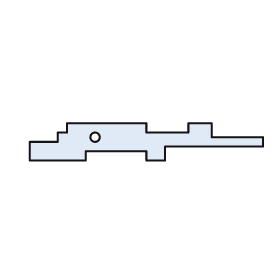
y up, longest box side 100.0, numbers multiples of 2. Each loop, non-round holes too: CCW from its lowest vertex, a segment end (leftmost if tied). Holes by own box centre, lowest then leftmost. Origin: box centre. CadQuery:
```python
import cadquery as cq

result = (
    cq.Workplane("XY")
    .moveTo(-50.0, -8.0)
    .lineTo(-26.0, -8.0)
    .lineTo(-26.0, -4.0)
    .lineTo(0.0, -4.0)
    .lineTo(0.0, -8.0)
    .lineTo(8.0, -8.0)
    .lineTo(8.0, -2.0)
    .lineTo(50.0, -2.0)
    .lineTo(50.0, 2.0)
    .lineTo(28.0, 2.0)
    .lineTo(28.0, 8.0)
    .lineTo(18.0, 8.0)
    .lineTo(18.0, 4.0)
    .lineTo(0.0, 4.0)
    .lineTo(0.0, 8.0)
    .lineTo(-34.0, 8.0)
    .lineTo(-34.0, 4.0)
    .lineTo(-38.0, 4.0)
    .lineTo(-38.0, 0.0)
    .lineTo(-50.0, 0.0)
    .close()
    .moveTo(-22.0, 2.0)
    .circle(2.0)
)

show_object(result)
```